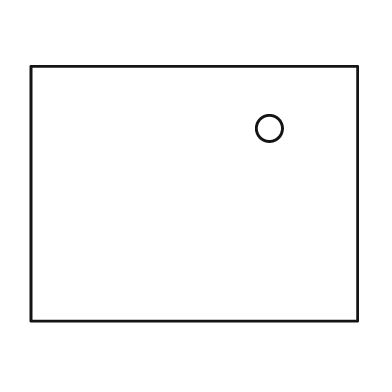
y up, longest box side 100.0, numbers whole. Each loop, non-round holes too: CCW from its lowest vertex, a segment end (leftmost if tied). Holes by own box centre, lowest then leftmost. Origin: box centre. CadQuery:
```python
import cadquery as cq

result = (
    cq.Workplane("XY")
    .moveTo(-50.0, -39.0)
    .lineTo(50.0, -39.0)
    .lineTo(50.0, 39.0)
    .lineTo(-50.0, 39.0)
    .close()
    .moveTo(23.0, 20.0)
    .circle(4.0)
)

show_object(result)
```